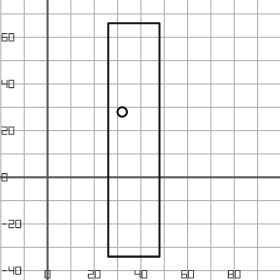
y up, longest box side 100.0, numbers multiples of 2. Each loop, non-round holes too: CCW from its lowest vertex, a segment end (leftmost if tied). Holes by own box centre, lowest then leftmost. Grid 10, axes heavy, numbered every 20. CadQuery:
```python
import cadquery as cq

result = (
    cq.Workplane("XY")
    .moveTo(26.0, -34.0)
    .lineTo(48.0, -34.0)
    .lineTo(48.0, 66.0)
    .lineTo(26.0, 66.0)
    .close()
    .moveTo(32.0, 28.0)
    .circle(2.0)
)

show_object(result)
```